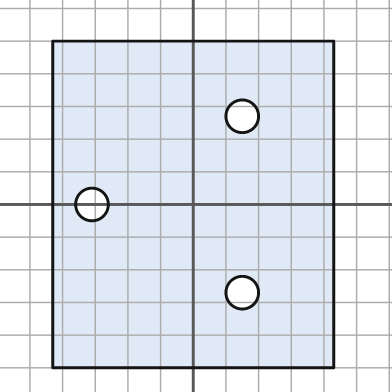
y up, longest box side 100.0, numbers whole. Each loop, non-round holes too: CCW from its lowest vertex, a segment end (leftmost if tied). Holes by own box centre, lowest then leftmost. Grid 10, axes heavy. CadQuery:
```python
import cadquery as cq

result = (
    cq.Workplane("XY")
    .moveTo(-43.0, -50.0)
    .lineTo(43.0, -50.0)
    .lineTo(43.0, 50.0)
    .lineTo(-43.0, 50.0)
    .close()
    .moveTo(15.0, -27.0)
    .circle(5.0)
    .moveTo(-31.0, 0.0)
    .circle(5.0)
    .moveTo(15.0, 27.0)
    .circle(5.0)
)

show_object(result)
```